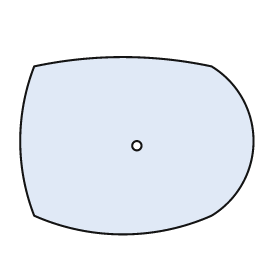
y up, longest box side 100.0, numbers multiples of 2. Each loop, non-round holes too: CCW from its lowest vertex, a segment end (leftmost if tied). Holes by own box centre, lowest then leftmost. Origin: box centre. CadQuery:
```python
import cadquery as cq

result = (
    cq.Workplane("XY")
    .moveTo(-44.0, -30.0)
    .threePointArc((-6.0, -38.0), (32.0, -30.0))
    .threePointArc((50.0, 2.0), (32.0, 34.0))
    .threePointArc((-6.0, 38.0), (-44.0, 34.0))
    .threePointArc((-50.0, 2.0), (-44.0, -30.0))
    .close()
    .moveTo(0.0, 0.0)
    .circle(2.0)
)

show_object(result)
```